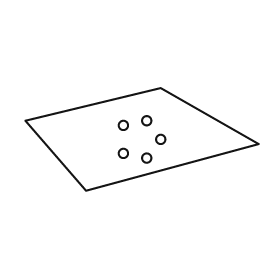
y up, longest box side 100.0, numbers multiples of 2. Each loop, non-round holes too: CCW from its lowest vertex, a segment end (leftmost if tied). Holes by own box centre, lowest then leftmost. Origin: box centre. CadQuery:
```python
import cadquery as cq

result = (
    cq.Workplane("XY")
    .moveTo(-24.0, -22.0)
    .lineTo(50.0, -2.0)
    .lineTo(8.0, 22.0)
    .lineTo(-50.0, 8.0)
    .close()
    .moveTo(2.0, -8.0)
    .circle(2.0)
    .moveTo(-8.0, -6.0)
    .circle(2.0)
    .moveTo(8.0, 0.0)
    .circle(2.0)
    .moveTo(-8.0, 6.0)
    .circle(2.0)
    .moveTo(2.0, 8.0)
    .circle(2.0)
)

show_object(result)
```